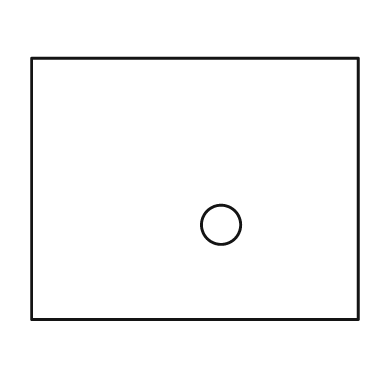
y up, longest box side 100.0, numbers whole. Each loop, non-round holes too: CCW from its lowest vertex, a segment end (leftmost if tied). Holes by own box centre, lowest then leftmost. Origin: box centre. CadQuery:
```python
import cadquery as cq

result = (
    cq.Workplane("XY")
    .moveTo(-50.0, -40.0)
    .lineTo(50.0, -40.0)
    .lineTo(50.0, 40.0)
    .lineTo(-50.0, 40.0)
    .close()
    .moveTo(8.0, -11.0)
    .circle(6.0)
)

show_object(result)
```